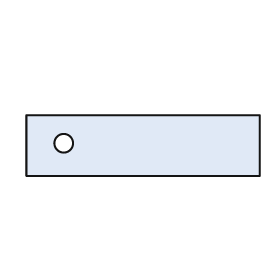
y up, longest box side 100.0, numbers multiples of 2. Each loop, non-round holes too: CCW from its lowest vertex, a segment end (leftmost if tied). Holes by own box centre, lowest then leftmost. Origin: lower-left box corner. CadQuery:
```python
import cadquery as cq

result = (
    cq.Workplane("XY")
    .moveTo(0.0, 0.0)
    .lineTo(100.0, 0.0)
    .lineTo(100.0, 26.0)
    .lineTo(0.0, 26.0)
    .close()
    .moveTo(16.0, 14.0)
    .circle(4.0)
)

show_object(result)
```